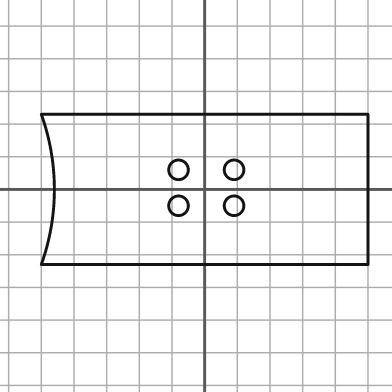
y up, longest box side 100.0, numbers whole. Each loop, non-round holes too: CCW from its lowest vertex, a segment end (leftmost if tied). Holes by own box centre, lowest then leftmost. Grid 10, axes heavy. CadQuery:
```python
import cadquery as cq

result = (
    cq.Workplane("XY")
    .moveTo(-50.0, -23.0)
    .lineTo(50.0, -23.0)
    .lineTo(50.0, 23.0)
    .lineTo(-50.0, 23.0)
    .threePointArc((-46.0, 0.0), (-50.0, -23.0))
    .close()
    .moveTo(-8.0, -5.0)
    .circle(3.0)
    .moveTo(9.0, -5.0)
    .circle(3.0)
    .moveTo(-8.0, 6.0)
    .circle(3.0)
    .moveTo(9.0, 6.0)
    .circle(3.0)
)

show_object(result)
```